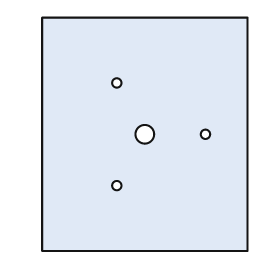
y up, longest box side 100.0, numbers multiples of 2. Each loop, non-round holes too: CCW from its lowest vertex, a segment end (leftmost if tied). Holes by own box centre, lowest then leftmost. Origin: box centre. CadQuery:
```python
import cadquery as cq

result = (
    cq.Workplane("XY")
    .moveTo(-44.0, -50.0)
    .lineTo(44.0, -50.0)
    .lineTo(44.0, 50.0)
    .lineTo(-44.0, 50.0)
    .close()
    .moveTo(-12.0, -22.0)
    .circle(2.0)
    .moveTo(0.0, 0.0)
    .circle(4.0)
    .moveTo(26.0, 0.0)
    .circle(2.0)
    .moveTo(-12.0, 22.0)
    .circle(2.0)
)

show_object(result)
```